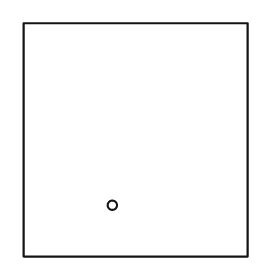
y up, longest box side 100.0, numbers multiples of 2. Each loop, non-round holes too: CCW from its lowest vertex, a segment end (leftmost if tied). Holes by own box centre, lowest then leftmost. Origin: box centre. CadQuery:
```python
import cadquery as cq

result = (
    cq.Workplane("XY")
    .moveTo(-48.0, -50.0)
    .lineTo(48.0, -50.0)
    .lineTo(48.0, 50.0)
    .lineTo(-48.0, 50.0)
    .close()
    .moveTo(-10.0, -28.0)
    .circle(2.0)
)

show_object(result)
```